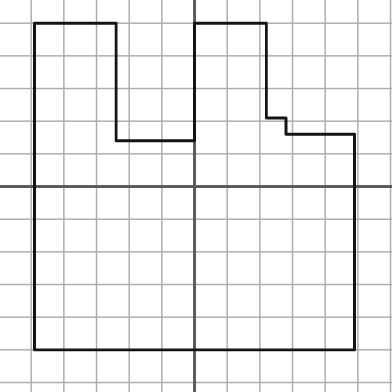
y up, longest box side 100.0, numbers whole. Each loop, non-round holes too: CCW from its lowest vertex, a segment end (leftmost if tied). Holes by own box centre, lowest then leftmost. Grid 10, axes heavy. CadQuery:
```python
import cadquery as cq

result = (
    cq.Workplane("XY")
    .moveTo(-49.0, -50.0)
    .lineTo(49.0, -50.0)
    .lineTo(49.0, 16.0)
    .lineTo(28.0, 16.0)
    .lineTo(28.0, 21.0)
    .lineTo(22.0, 21.0)
    .lineTo(22.0, 50.0)
    .lineTo(0.0, 50.0)
    .lineTo(0.0, 14.0)
    .lineTo(-24.0, 14.0)
    .lineTo(-24.0, 50.0)
    .lineTo(-49.0, 50.0)
    .close()
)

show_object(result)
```